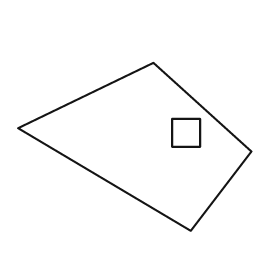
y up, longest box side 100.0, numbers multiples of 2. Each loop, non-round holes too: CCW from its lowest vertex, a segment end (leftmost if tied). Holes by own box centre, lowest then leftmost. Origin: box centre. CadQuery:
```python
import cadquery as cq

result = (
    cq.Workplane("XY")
    .moveTo(24.0, -36.0)
    .lineTo(50.0, -2.0)
    .lineTo(8.0, 36.0)
    .lineTo(-50.0, 8.0)
    .close()
    .moveTo(16.0, 0.0)
    .lineTo(28.0, 0.0)
    .lineTo(28.0, 12.0)
    .lineTo(16.0, 12.0)
    .close()
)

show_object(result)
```